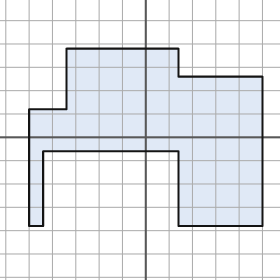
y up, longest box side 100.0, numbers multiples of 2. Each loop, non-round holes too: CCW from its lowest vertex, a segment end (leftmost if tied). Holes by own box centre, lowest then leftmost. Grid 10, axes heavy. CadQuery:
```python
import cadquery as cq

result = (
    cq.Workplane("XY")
    .moveTo(-50.0, -38.0)
    .lineTo(-44.0, -38.0)
    .lineTo(-44.0, -6.0)
    .lineTo(14.0, -6.0)
    .lineTo(14.0, -38.0)
    .lineTo(50.0, -38.0)
    .lineTo(50.0, 26.0)
    .lineTo(14.0, 26.0)
    .lineTo(14.0, 38.0)
    .lineTo(-34.0, 38.0)
    .lineTo(-34.0, 12.0)
    .lineTo(-50.0, 12.0)
    .close()
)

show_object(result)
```